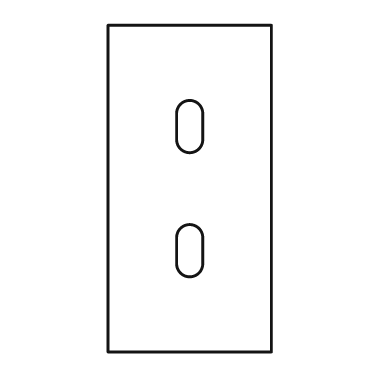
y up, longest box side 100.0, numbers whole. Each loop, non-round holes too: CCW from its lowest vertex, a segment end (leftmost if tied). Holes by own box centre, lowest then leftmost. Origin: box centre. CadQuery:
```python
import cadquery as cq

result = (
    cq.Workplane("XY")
    .moveTo(-25.0, -50.0)
    .lineTo(25.0, -50.0)
    .lineTo(25.0, 50.0)
    .lineTo(-25.0, 50.0)
    .close()
    .moveTo(-4.0, -23.0)
    .threePointArc((0.0, -27.0), (4.0, -23.0))
    .lineTo(4.0, -15.0)
    .threePointArc((0.0, -11.0), (-4.0, -15.0))
    .close()
    .moveTo(-4.0, 15.0)
    .threePointArc((0.0, 11.0), (4.0, 15.0))
    .lineTo(4.0, 23.0)
    .threePointArc((0.0, 27.0), (-4.0, 23.0))
    .close()
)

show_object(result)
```